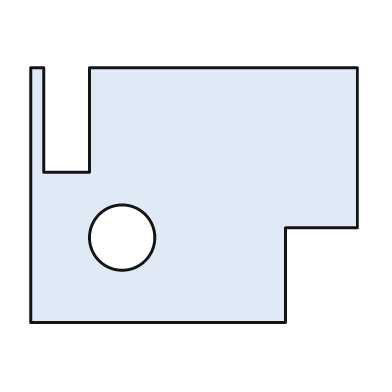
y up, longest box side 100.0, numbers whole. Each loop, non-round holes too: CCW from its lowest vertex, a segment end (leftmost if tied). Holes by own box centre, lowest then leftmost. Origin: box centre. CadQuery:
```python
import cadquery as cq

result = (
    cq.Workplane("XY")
    .moveTo(-50.0, -39.0)
    .lineTo(28.0, -39.0)
    .lineTo(28.0, -10.0)
    .lineTo(50.0, -10.0)
    .lineTo(50.0, 39.0)
    .lineTo(-32.0, 39.0)
    .lineTo(-32.0, 7.0)
    .lineTo(-46.0, 7.0)
    .lineTo(-46.0, 39.0)
    .lineTo(-50.0, 39.0)
    .close()
    .moveTo(-22.0, -13.0)
    .circle(10.0)
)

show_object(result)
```